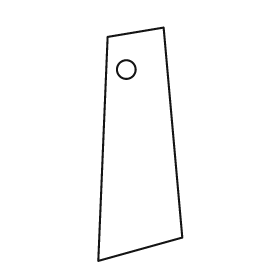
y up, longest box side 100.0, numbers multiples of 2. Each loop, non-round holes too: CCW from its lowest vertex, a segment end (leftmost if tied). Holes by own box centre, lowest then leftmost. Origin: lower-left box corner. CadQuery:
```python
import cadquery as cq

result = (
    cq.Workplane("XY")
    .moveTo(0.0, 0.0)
    .lineTo(36.0, 10.0)
    .lineTo(28.0, 100.0)
    .lineTo(4.0, 96.0)
    .close()
    .moveTo(12.0, 82.0)
    .circle(4.0)
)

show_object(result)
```